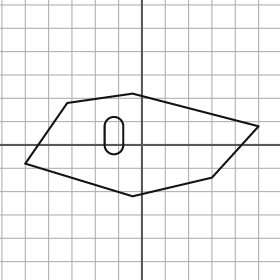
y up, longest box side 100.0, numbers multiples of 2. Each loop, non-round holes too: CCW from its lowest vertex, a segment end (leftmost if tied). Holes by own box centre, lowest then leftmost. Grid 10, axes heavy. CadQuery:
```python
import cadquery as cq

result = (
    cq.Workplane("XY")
    .moveTo(-4.0, -22.0)
    .lineTo(30.0, -14.0)
    .lineTo(50.0, 8.0)
    .lineTo(-4.0, 22.0)
    .lineTo(-32.0, 18.0)
    .lineTo(-50.0, -8.0)
    .close()
    .moveTo(-16.0, 0.0)
    .threePointArc((-12.0, -4.0), (-8.0, 0.0))
    .lineTo(-8.0, 8.0)
    .threePointArc((-12.0, 12.0), (-16.0, 8.0))
    .close()
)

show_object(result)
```